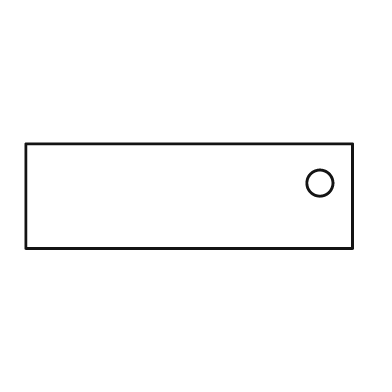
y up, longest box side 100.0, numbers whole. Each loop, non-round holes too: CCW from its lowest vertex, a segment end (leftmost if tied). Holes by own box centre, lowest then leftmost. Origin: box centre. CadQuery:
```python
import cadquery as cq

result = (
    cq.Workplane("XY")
    .moveTo(-50.0, -16.0)
    .lineTo(50.0, -16.0)
    .lineTo(50.0, 16.0)
    .lineTo(-50.0, 16.0)
    .close()
    .moveTo(40.0, 4.0)
    .circle(4.0)
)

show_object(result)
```